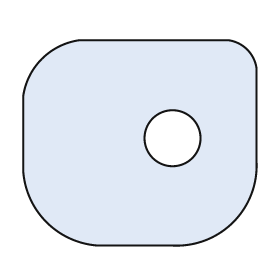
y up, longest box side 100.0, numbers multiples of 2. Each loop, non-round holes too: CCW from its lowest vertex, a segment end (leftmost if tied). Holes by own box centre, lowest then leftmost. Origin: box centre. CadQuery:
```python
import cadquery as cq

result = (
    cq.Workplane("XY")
    .moveTo(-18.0, -44.0)
    .lineTo(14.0, -44.0)
    .threePointArc((40.0, -34.0), (50.0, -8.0))
    .lineTo(50.0, 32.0)
    .threePointArc((46.0, 40.0), (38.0, 44.0))
    .lineTo(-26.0, 44.0)
    .threePointArc((-42.0, 36.0), (-50.0, 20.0))
    .lineTo(-50.0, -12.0)
    .threePointArc((-40.0, -34.0), (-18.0, -44.0))
    .close()
    .moveTo(14.0, 2.0)
    .circle(12.0)
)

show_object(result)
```